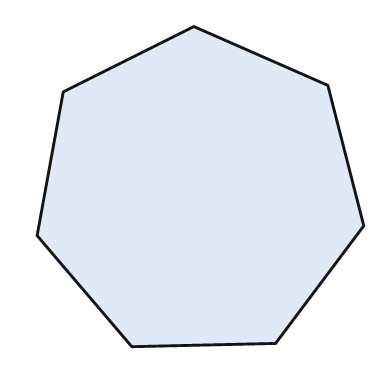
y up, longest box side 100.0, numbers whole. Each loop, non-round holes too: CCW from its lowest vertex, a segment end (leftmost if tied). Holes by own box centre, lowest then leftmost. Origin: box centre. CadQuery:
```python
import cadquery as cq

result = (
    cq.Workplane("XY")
    .moveTo(-21.0, -49.0)
    .lineTo(23.0, -48.0)
    .lineTo(50.0, -12.0)
    .lineTo(39.0, 31.0)
    .lineTo(-2.0, 49.0)
    .lineTo(-42.0, 29.0)
    .lineTo(-50.0, -15.0)
    .close()
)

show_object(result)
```